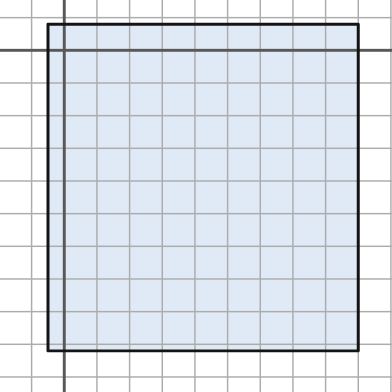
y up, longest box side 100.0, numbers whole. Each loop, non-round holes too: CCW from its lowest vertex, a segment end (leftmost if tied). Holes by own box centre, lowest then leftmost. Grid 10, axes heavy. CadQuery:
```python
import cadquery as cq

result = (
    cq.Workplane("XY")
    .moveTo(-5.0, -92.0)
    .lineTo(90.0, -92.0)
    .lineTo(90.0, 8.0)
    .lineTo(-5.0, 8.0)
    .close()
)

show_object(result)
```